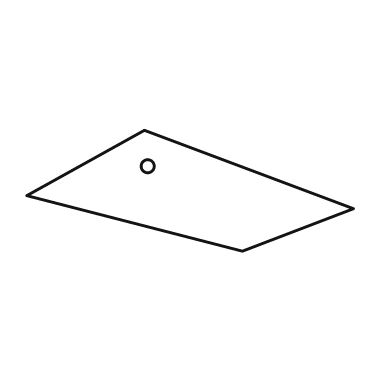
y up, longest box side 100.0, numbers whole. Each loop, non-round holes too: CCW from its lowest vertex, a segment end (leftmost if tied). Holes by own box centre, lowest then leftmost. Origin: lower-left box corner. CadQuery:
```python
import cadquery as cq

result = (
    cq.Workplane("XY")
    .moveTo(66.0, 0.0)
    .lineTo(100.0, 13.0)
    .lineTo(36.0, 37.0)
    .lineTo(0.0, 17.0)
    .close()
    .moveTo(37.0, 26.0)
    .circle(2.0)
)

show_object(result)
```